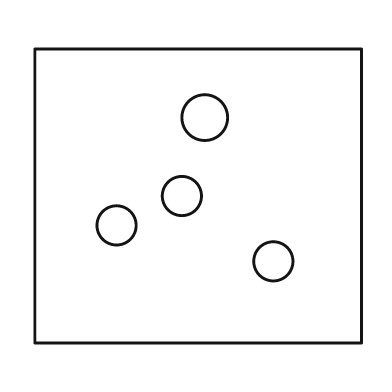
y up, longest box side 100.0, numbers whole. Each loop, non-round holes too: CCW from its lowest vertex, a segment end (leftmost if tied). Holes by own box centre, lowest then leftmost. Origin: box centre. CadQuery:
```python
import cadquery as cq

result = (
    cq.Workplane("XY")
    .moveTo(-50.0, -45.0)
    .lineTo(50.0, -45.0)
    .lineTo(50.0, 45.0)
    .lineTo(-50.0, 45.0)
    .close()
    .moveTo(23.0, -20.0)
    .circle(6.0)
    .moveTo(-25.0, -9.0)
    .circle(6.0)
    .moveTo(-5.0, 0.0)
    .circle(6.0)
    .moveTo(2.0, 24.0)
    .circle(7.0)
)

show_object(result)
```